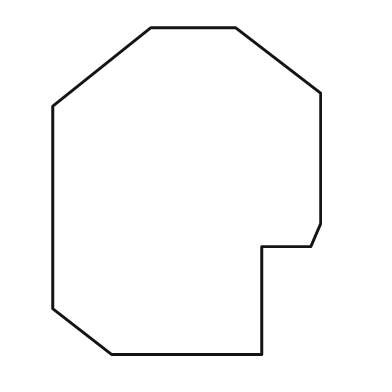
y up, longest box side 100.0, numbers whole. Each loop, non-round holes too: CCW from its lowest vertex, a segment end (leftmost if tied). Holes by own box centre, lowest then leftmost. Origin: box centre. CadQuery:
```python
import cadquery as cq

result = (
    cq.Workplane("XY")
    .moveTo(-23.0, -50.0)
    .lineTo(23.0, -50.0)
    .lineTo(23.0, -17.0)
    .lineTo(38.0, -17.0)
    .lineTo(41.0, -10.0)
    .lineTo(41.0, 30.0)
    .lineTo(15.0, 50.0)
    .lineTo(-11.0, 50.0)
    .lineTo(-41.0, 26.0)
    .lineTo(-41.0, -36.0)
    .close()
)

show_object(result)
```